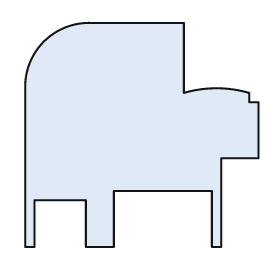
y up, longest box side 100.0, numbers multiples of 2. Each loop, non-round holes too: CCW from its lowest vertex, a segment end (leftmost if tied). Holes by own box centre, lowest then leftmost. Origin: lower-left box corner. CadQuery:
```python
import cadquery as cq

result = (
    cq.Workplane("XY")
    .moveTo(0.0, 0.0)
    .lineTo(4.0, 0.0)
    .lineTo(4.0, 20.0)
    .lineTo(26.0, 20.0)
    .lineTo(26.0, 0.0)
    .lineTo(38.0, 0.0)
    .lineTo(38.0, 24.0)
    .lineTo(80.0, 24.0)
    .lineTo(80.0, 0.0)
    .lineTo(84.0, 0.0)
    .lineTo(84.0, 38.0)
    .lineTo(100.0, 38.0)
    .lineTo(100.0, 62.0)
    .lineTo(96.0, 62.0)
    .lineTo(96.0, 66.0)
    .threePointArc((82.0, 68.0), (68.0, 66.0))
    .lineTo(68.0, 96.0)
    .lineTo(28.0, 96.0)
    .threePointArc((8.0, 88.0), (0.0, 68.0))
    .close()
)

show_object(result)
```